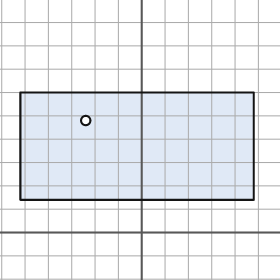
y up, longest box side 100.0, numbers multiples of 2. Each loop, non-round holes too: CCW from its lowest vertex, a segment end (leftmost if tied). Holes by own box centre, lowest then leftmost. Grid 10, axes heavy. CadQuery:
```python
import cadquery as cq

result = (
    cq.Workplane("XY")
    .moveTo(-52.0, 14.0)
    .lineTo(48.0, 14.0)
    .lineTo(48.0, 60.0)
    .lineTo(-52.0, 60.0)
    .close()
    .moveTo(-24.0, 48.0)
    .circle(2.0)
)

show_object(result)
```